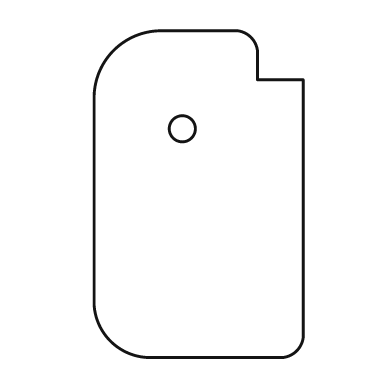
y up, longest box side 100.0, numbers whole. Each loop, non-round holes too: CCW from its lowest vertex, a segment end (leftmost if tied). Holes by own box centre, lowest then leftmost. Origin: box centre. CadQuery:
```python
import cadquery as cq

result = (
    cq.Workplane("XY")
    .moveTo(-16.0, -50.0)
    .lineTo(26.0, -50.0)
    .threePointArc((30.0, -48.0), (32.0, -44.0))
    .lineTo(32.0, 35.0)
    .lineTo(18.0, 35.0)
    .lineTo(18.0, 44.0)
    .threePointArc((16.0, 48.0), (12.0, 50.0))
    .lineTo(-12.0, 50.0)
    .threePointArc((-26.0, 44.0), (-32.0, 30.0))
    .lineTo(-32.0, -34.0)
    .threePointArc((-27.0, -45.0), (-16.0, -50.0))
    .close()
    .moveTo(-5.0, 20.0)
    .circle(4.0)
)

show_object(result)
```